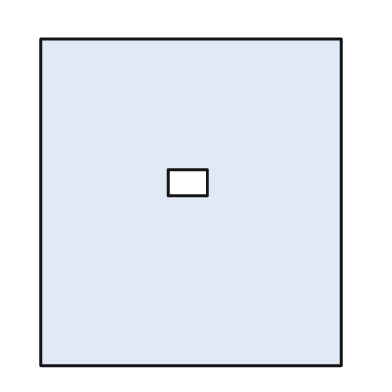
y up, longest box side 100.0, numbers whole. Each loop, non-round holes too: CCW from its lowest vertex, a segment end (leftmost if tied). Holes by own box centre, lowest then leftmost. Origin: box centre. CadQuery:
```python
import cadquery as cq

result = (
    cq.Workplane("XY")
    .moveTo(-46.0, -50.0)
    .lineTo(46.0, -50.0)
    .lineTo(46.0, 50.0)
    .lineTo(-46.0, 50.0)
    .close()
    .moveTo(-7.0, 2.0)
    .lineTo(5.0, 2.0)
    .lineTo(5.0, 10.0)
    .lineTo(-7.0, 10.0)
    .close()
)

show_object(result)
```